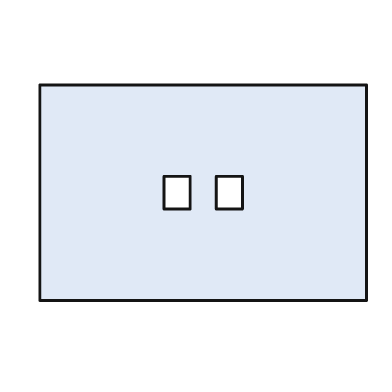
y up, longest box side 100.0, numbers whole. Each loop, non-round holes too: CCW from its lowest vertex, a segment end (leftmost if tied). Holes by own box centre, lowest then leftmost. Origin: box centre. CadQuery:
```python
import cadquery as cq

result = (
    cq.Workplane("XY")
    .moveTo(-50.0, -33.0)
    .lineTo(50.0, -33.0)
    .lineTo(50.0, 33.0)
    .lineTo(-50.0, 33.0)
    .close()
    .moveTo(-12.0, -5.0)
    .lineTo(-4.0, -5.0)
    .lineTo(-4.0, 5.0)
    .lineTo(-12.0, 5.0)
    .close()
    .moveTo(4.0, -5.0)
    .lineTo(12.0, -5.0)
    .lineTo(12.0, 5.0)
    .lineTo(4.0, 5.0)
    .close()
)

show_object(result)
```